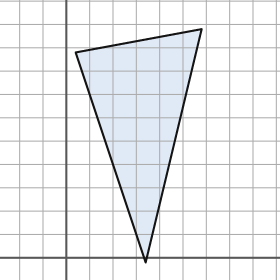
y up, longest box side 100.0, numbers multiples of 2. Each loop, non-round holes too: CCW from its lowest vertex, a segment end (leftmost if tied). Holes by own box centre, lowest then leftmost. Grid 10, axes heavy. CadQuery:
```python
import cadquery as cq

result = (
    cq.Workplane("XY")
    .moveTo(34.0, -2.0)
    .lineTo(58.0, 98.0)
    .lineTo(4.0, 88.0)
    .close()
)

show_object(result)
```